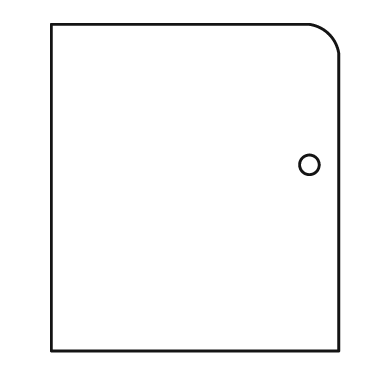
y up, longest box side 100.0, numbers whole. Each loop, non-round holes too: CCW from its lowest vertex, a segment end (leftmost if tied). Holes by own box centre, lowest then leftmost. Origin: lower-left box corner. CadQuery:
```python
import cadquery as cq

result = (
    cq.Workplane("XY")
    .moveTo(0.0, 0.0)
    .lineTo(88.0, 0.0)
    .lineTo(88.0, 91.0)
    .threePointArc((85.0, 97.0), (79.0, 100.0))
    .lineTo(0.0, 100.0)
    .close()
    .moveTo(79.0, 57.0)
    .circle(3.0)
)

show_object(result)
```